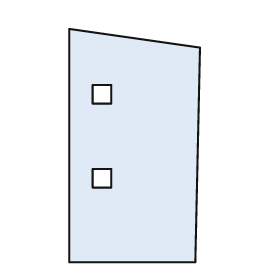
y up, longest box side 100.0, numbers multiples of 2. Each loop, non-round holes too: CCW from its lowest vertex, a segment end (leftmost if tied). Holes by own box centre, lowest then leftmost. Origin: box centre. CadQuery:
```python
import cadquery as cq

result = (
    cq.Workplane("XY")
    .moveTo(-28.0, -50.0)
    .lineTo(26.0, -50.0)
    .lineTo(28.0, 42.0)
    .lineTo(-28.0, 50.0)
    .close()
    .moveTo(-18.0, -18.0)
    .lineTo(-10.0, -18.0)
    .lineTo(-10.0, -10.0)
    .lineTo(-18.0, -10.0)
    .close()
    .moveTo(-18.0, 18.0)
    .lineTo(-10.0, 18.0)
    .lineTo(-10.0, 26.0)
    .lineTo(-18.0, 26.0)
    .close()
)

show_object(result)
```